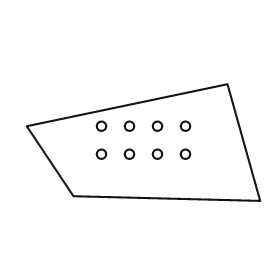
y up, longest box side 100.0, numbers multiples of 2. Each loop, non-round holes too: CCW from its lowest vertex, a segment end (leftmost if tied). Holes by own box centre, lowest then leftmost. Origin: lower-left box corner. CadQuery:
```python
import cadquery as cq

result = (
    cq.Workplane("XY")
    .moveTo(100.0, 0.0)
    .lineTo(86.0, 50.0)
    .lineTo(0.0, 32.0)
    .lineTo(20.0, 2.0)
    .close()
    .moveTo(32.0, 20.0)
    .circle(2.0)
    .moveTo(44.0, 20.0)
    .circle(2.0)
    .moveTo(56.0, 20.0)
    .circle(2.0)
    .moveTo(68.0, 20.0)
    .circle(2.0)
    .moveTo(32.0, 32.0)
    .circle(2.0)
    .moveTo(44.0, 32.0)
    .circle(2.0)
    .moveTo(56.0, 32.0)
    .circle(2.0)
    .moveTo(68.0, 32.0)
    .circle(2.0)
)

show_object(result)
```